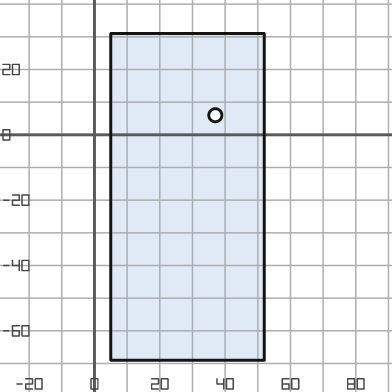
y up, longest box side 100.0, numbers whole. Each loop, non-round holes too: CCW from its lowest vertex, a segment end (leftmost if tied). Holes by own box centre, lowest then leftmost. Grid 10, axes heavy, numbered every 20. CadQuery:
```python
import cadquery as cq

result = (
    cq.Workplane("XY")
    .moveTo(5.0, -69.0)
    .lineTo(52.0, -69.0)
    .lineTo(52.0, 31.0)
    .lineTo(5.0, 31.0)
    .close()
    .moveTo(37.0, 6.0)
    .circle(2.0)
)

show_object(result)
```